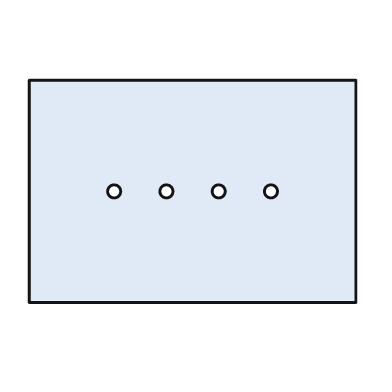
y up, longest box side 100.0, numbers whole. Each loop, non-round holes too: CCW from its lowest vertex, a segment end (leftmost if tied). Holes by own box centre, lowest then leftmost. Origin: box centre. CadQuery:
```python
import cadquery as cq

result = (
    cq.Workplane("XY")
    .moveTo(-50.0, -34.0)
    .lineTo(50.0, -34.0)
    .lineTo(50.0, 34.0)
    .lineTo(-50.0, 34.0)
    .close()
    .moveTo(-24.0, 0.0)
    .circle(2.0)
    .moveTo(-8.0, 0.0)
    .circle(2.0)
    .moveTo(8.0, 0.0)
    .circle(2.0)
    .moveTo(24.0, 0.0)
    .circle(2.0)
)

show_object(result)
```